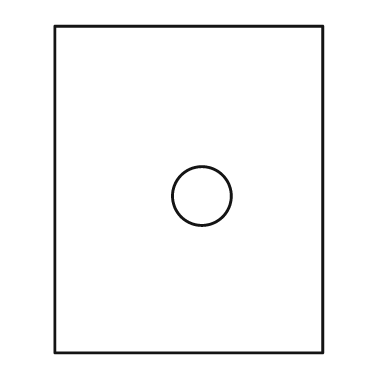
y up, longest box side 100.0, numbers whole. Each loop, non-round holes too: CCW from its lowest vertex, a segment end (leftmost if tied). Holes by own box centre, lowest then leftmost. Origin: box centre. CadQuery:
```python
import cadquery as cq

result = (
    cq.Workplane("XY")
    .moveTo(-41.0, -50.0)
    .lineTo(41.0, -50.0)
    .lineTo(41.0, 50.0)
    .lineTo(-41.0, 50.0)
    .close()
    .moveTo(4.0, -2.0)
    .circle(9.0)
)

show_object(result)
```